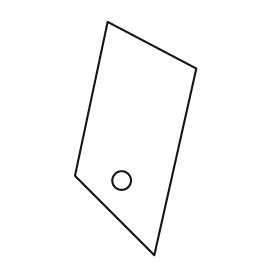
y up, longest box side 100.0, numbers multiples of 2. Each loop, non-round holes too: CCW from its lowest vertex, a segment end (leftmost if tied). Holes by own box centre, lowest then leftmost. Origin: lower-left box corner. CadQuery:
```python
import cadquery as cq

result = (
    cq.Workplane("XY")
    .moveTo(34.0, 0.0)
    .lineTo(52.0, 80.0)
    .lineTo(14.0, 100.0)
    .lineTo(0.0, 34.0)
    .close()
    .moveTo(20.0, 32.0)
    .circle(4.0)
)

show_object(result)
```